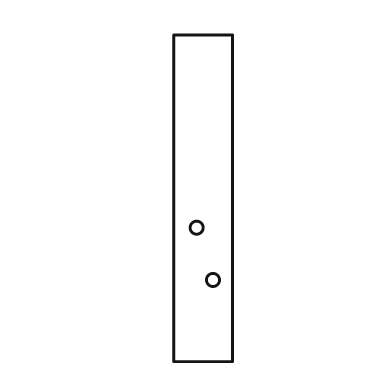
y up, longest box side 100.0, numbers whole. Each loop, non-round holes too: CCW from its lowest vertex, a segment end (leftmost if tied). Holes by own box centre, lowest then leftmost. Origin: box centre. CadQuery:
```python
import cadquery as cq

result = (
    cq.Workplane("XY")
    .moveTo(-9.0, -50.0)
    .lineTo(9.0, -50.0)
    .lineTo(9.0, 50.0)
    .lineTo(-9.0, 50.0)
    .close()
    .moveTo(3.0, -25.0)
    .circle(2.0)
    .moveTo(-2.0, -9.0)
    .circle(2.0)
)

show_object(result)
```